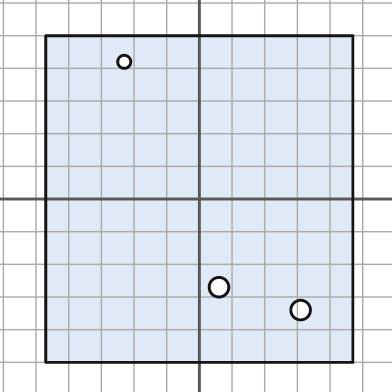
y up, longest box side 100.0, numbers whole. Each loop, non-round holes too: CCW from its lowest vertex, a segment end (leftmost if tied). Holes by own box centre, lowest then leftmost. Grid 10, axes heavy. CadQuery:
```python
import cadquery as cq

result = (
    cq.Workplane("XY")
    .moveTo(-47.0, -50.0)
    .lineTo(47.0, -50.0)
    .lineTo(47.0, 50.0)
    .lineTo(-47.0, 50.0)
    .close()
    .moveTo(31.0, -34.0)
    .circle(3.0)
    .moveTo(6.0, -27.0)
    .circle(3.0)
    .moveTo(-23.0, 42.0)
    .circle(2.0)
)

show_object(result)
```